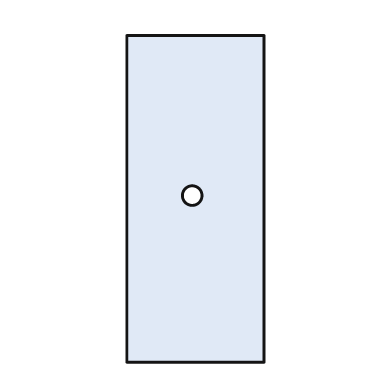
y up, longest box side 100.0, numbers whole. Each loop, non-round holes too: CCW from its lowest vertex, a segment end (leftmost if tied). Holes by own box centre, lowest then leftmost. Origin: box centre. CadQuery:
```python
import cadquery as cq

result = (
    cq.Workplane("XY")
    .moveTo(-21.0, -50.0)
    .lineTo(21.0, -50.0)
    .lineTo(21.0, 50.0)
    .lineTo(-21.0, 50.0)
    .close()
    .moveTo(-1.0, 1.0)
    .circle(3.0)
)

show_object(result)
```